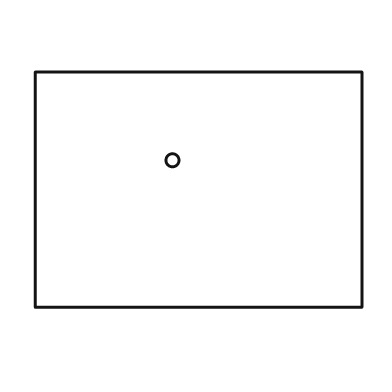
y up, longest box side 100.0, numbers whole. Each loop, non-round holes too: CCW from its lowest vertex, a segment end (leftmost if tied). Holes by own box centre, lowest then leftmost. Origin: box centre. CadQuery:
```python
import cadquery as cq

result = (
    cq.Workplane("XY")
    .moveTo(-50.0, -36.0)
    .lineTo(50.0, -36.0)
    .lineTo(50.0, 36.0)
    .lineTo(-50.0, 36.0)
    .close()
    .moveTo(-8.0, 9.0)
    .circle(2.0)
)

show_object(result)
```